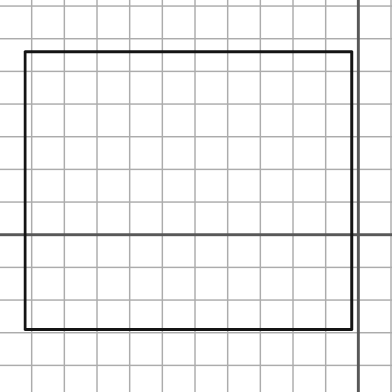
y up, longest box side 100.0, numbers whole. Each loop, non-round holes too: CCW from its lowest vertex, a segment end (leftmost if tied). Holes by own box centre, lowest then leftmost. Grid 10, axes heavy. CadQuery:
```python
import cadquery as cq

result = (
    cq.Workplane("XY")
    .moveTo(-102.0, -29.0)
    .lineTo(-2.0, -29.0)
    .lineTo(-2.0, 56.0)
    .lineTo(-102.0, 56.0)
    .close()
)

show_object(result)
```